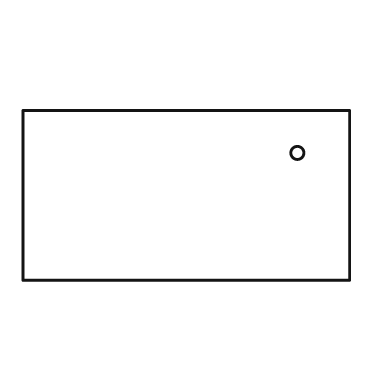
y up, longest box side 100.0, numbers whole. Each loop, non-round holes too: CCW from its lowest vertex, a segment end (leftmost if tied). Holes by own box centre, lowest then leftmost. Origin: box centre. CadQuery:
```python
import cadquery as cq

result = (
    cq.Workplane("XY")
    .moveTo(-50.0, -26.0)
    .lineTo(50.0, -26.0)
    .lineTo(50.0, 26.0)
    .lineTo(-50.0, 26.0)
    .close()
    .moveTo(34.0, 13.0)
    .circle(2.0)
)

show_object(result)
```